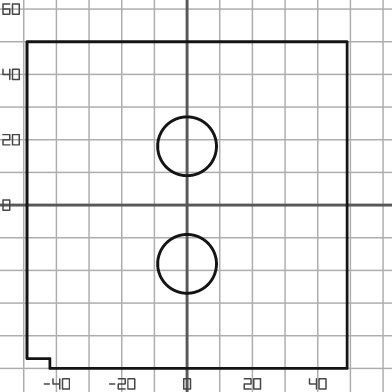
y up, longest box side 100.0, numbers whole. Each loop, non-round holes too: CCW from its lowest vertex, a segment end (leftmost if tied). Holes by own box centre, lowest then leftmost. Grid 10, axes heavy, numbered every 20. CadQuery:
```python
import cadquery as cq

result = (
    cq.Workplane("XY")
    .moveTo(-42.0, -50.0)
    .lineTo(49.0, -50.0)
    .lineTo(49.0, 50.0)
    .lineTo(-49.0, 50.0)
    .lineTo(-49.0, -47.0)
    .lineTo(-42.0, -47.0)
    .close()
    .moveTo(0.0, -18.0)
    .circle(9.0)
    .moveTo(0.0, 18.0)
    .circle(9.0)
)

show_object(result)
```